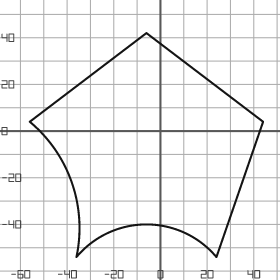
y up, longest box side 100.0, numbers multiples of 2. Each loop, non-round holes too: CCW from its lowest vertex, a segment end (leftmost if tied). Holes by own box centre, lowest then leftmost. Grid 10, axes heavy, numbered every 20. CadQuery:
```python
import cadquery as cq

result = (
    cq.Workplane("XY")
    .moveTo(-36.0, -54.0)
    .threePointArc((-6.0, -40.0), (24.0, -54.0))
    .lineTo(44.0, 4.0)
    .lineTo(-6.0, 42.0)
    .lineTo(-56.0, 4.0)
    .threePointArc((-38.0, -22.0), (-36.0, -54.0))
    .close()
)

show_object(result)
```